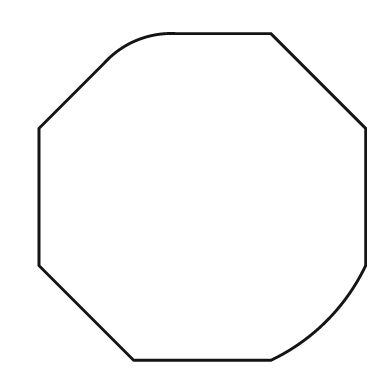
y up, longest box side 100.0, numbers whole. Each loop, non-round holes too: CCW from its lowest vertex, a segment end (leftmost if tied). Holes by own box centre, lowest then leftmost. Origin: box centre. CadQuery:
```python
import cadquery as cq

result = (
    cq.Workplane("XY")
    .moveTo(-21.0, -50.0)
    .lineTo(21.0, -50.0)
    .threePointArc((38.0, -38.0), (50.0, -21.0))
    .lineTo(50.0, 21.0)
    .lineTo(21.0, 50.0)
    .lineTo(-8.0, 50.0)
    .threePointArc((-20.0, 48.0), (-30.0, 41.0))
    .lineTo(-50.0, 21.0)
    .lineTo(-50.0, -21.0)
    .close()
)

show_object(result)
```